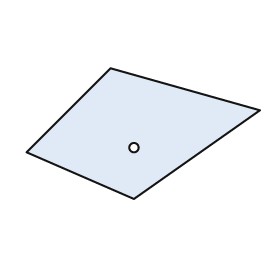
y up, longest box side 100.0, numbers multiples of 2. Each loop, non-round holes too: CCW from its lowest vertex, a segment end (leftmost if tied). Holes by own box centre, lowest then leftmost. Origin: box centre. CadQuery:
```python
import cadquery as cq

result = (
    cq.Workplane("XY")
    .moveTo(-4.0, -28.0)
    .lineTo(50.0, 10.0)
    .lineTo(-14.0, 28.0)
    .lineTo(-50.0, -8.0)
    .close()
    .moveTo(-4.0, -6.0)
    .circle(2.0)
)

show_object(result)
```